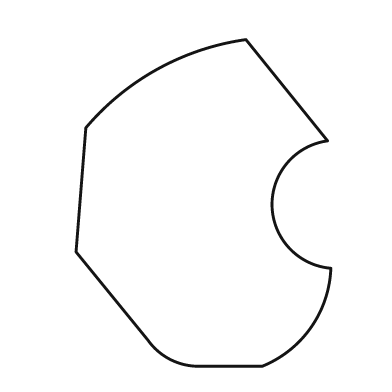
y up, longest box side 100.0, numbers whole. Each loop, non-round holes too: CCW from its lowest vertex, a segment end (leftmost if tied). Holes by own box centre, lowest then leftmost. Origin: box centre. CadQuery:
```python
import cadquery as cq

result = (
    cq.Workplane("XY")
    .moveTo(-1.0, -50.0)
    .lineTo(18.0, -50.0)
    .threePointArc((33.0, -38.0), (39.0, -20.0))
    .threePointArc((21.0, -1.0), (38.0, 19.0))
    .lineTo(13.0, 50.0)
    .threePointArc((-14.0, 41.0), (-36.0, 23.0))
    .lineTo(-39.0, -15.0)
    .lineTo(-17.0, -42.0)
    .threePointArc((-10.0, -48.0), (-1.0, -50.0))
    .close()
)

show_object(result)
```